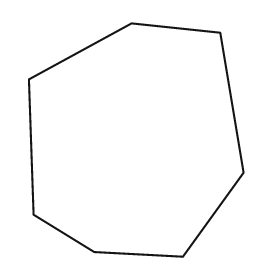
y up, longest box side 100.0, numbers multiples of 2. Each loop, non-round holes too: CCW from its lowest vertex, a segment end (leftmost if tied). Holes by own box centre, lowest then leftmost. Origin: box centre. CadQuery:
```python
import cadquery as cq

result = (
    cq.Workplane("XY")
    .moveTo(20.0, -50.0)
    .lineTo(46.0, -14.0)
    .lineTo(36.0, 46.0)
    .lineTo(-2.0, 50.0)
    .lineTo(-46.0, 26.0)
    .lineTo(-44.0, -32.0)
    .lineTo(-18.0, -48.0)
    .close()
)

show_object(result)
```